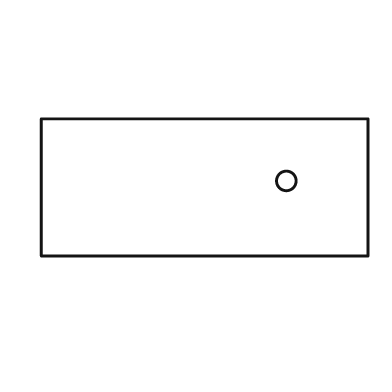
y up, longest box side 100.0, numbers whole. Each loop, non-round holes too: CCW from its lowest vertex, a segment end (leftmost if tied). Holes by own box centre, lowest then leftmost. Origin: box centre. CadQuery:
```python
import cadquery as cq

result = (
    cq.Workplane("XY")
    .moveTo(-50.0, -21.0)
    .lineTo(50.0, -21.0)
    .lineTo(50.0, 21.0)
    .lineTo(-50.0, 21.0)
    .close()
    .moveTo(25.0, 2.0)
    .circle(3.0)
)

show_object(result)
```